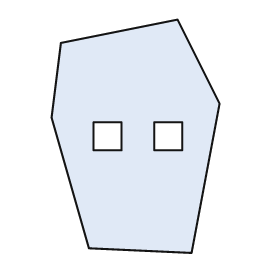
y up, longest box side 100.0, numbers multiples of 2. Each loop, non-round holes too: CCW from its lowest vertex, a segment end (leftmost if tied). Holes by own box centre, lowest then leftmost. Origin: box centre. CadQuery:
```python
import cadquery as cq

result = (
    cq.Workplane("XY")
    .moveTo(24.0, -50.0)
    .lineTo(36.0, 14.0)
    .lineTo(18.0, 50.0)
    .lineTo(-32.0, 40.0)
    .lineTo(-36.0, 8.0)
    .lineTo(-20.0, -48.0)
    .close()
    .moveTo(-18.0, -6.0)
    .lineTo(-6.0, -6.0)
    .lineTo(-6.0, 6.0)
    .lineTo(-18.0, 6.0)
    .close()
    .moveTo(8.0, -6.0)
    .lineTo(20.0, -6.0)
    .lineTo(20.0, 6.0)
    .lineTo(8.0, 6.0)
    .close()
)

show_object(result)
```